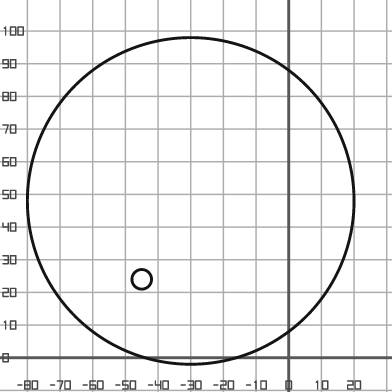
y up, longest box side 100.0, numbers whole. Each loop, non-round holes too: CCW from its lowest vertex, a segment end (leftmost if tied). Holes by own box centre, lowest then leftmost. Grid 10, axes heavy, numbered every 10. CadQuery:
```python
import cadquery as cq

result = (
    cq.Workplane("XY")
    .moveTo(-30.0, 48.0)
    .circle(50.0)
    .moveTo(-45.0, 24.0)
    .circle(3.0)
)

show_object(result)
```